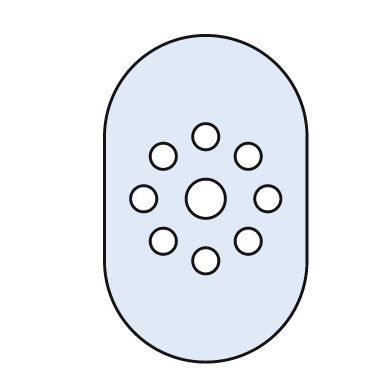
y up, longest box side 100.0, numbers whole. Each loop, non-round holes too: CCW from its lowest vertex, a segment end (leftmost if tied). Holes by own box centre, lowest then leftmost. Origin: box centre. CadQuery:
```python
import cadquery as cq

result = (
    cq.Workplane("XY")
    .moveTo(-31.0, -19.0)
    .threePointArc((0.0, -50.0), (31.0, -19.0))
    .lineTo(31.0, 19.0)
    .threePointArc((0.0, 50.0), (-31.0, 19.0))
    .close()
    .moveTo(0.0, -19.0)
    .circle(4.0)
    .moveTo(-13.0, -13.0)
    .circle(4.0)
    .moveTo(13.0, -13.0)
    .circle(4.0)
    .moveTo(-19.0, 0.0)
    .circle(4.0)
    .moveTo(0.0, 0.0)
    .circle(6.0)
    .moveTo(19.0, 0.0)
    .circle(4.0)
    .moveTo(-13.0, 13.0)
    .circle(4.0)
    .moveTo(13.0, 13.0)
    .circle(4.0)
    .moveTo(0.0, 19.0)
    .circle(4.0)
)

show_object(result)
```